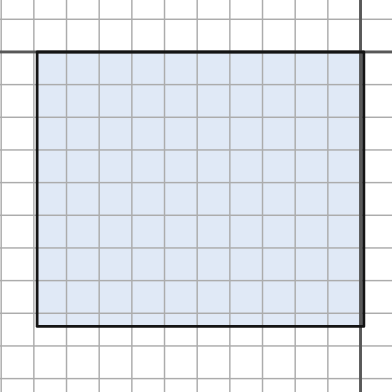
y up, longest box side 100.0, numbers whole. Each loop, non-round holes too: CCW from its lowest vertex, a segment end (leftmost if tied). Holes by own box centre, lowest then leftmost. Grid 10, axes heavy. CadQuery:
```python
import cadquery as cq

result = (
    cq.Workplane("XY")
    .moveTo(-99.0, -84.0)
    .lineTo(1.0, -84.0)
    .lineTo(1.0, 0.0)
    .lineTo(-99.0, 0.0)
    .close()
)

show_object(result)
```